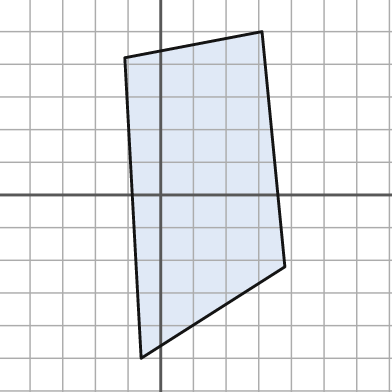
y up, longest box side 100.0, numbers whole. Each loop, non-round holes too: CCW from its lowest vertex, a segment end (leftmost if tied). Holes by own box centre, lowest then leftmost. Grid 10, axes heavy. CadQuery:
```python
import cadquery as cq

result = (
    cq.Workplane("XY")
    .moveTo(-6.0, -50.0)
    .lineTo(38.0, -22.0)
    .lineTo(31.0, 50.0)
    .lineTo(-11.0, 42.0)
    .close()
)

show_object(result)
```